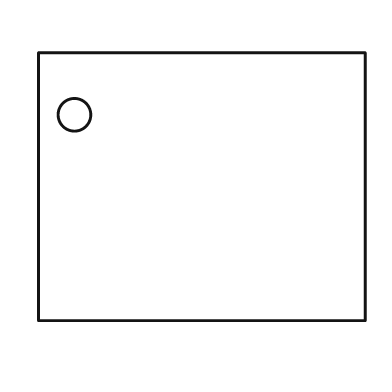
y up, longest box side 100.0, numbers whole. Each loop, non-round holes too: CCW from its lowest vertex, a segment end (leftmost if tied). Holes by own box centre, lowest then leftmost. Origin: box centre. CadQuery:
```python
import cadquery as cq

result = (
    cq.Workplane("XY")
    .moveTo(-50.0, -41.0)
    .lineTo(50.0, -41.0)
    .lineTo(50.0, 41.0)
    .lineTo(-50.0, 41.0)
    .close()
    .moveTo(-39.0, 22.0)
    .circle(5.0)
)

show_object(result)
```